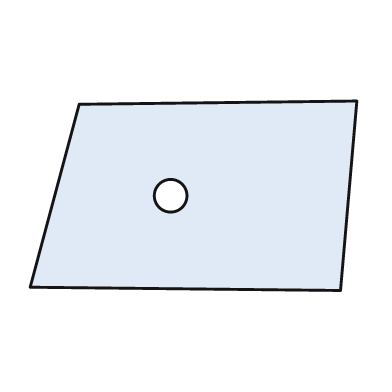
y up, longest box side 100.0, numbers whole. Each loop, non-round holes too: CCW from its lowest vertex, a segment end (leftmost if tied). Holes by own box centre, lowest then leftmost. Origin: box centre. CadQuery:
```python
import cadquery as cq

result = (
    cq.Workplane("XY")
    .moveTo(45.0, -29.0)
    .lineTo(50.0, 29.0)
    .lineTo(-35.0, 28.0)
    .lineTo(-50.0, -28.0)
    .close()
    .moveTo(-7.0, 0.0)
    .circle(5.0)
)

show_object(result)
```